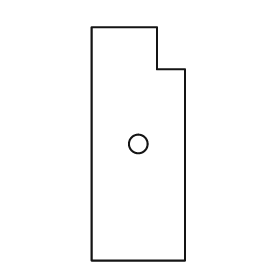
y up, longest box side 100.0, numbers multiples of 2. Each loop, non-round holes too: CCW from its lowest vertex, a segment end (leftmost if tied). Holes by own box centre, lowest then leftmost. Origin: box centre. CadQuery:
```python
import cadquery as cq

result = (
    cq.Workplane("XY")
    .moveTo(-20.0, -50.0)
    .lineTo(20.0, -50.0)
    .lineTo(20.0, 32.0)
    .lineTo(8.0, 32.0)
    .lineTo(8.0, 50.0)
    .lineTo(-20.0, 50.0)
    .close()
    .moveTo(0.0, 0.0)
    .circle(4.0)
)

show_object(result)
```